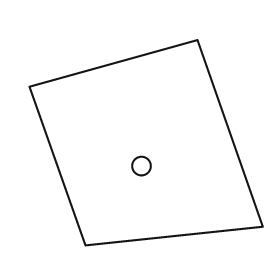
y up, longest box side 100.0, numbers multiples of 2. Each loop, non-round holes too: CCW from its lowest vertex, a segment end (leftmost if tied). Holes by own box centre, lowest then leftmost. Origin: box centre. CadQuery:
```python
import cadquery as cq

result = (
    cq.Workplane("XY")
    .moveTo(-26.0, -44.0)
    .lineTo(50.0, -36.0)
    .lineTo(22.0, 44.0)
    .lineTo(-50.0, 24.0)
    .close()
    .moveTo(-2.0, -10.0)
    .circle(4.0)
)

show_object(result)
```